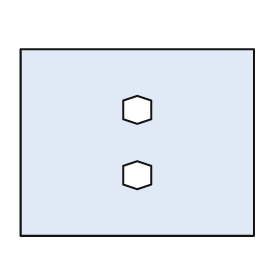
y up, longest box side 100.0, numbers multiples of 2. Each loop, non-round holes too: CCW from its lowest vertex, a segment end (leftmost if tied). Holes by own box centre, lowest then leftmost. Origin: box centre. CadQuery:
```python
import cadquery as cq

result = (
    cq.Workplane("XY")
    .moveTo(-50.0, -40.0)
    .lineTo(50.0, -40.0)
    .lineTo(50.0, 40.0)
    .lineTo(-50.0, 40.0)
    .close()
    .moveTo(0.0, -20.0)
    .lineTo(6.0, -18.0)
    .lineTo(6.0, -10.0)
    .lineTo(0.0, -8.0)
    .lineTo(-6.0, -10.0)
    .lineTo(-6.0, -18.0)
    .close()
    .moveTo(0.0, 8.0)
    .lineTo(6.0, 10.0)
    .lineTo(6.0, 18.0)
    .lineTo(0.0, 20.0)
    .lineTo(-6.0, 18.0)
    .lineTo(-6.0, 10.0)
    .close()
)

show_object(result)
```